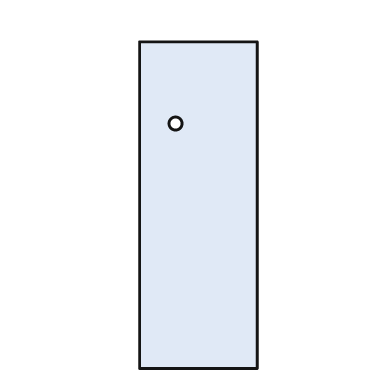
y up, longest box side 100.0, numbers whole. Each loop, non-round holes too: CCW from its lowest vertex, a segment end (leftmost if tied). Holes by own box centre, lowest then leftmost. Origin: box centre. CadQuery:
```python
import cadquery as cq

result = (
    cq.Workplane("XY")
    .moveTo(-18.0, -50.0)
    .lineTo(18.0, -50.0)
    .lineTo(18.0, 50.0)
    .lineTo(-18.0, 50.0)
    .close()
    .moveTo(-7.0, 25.0)
    .circle(2.0)
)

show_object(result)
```